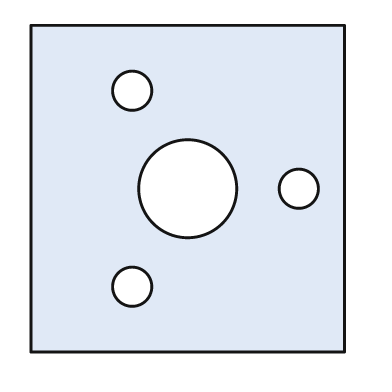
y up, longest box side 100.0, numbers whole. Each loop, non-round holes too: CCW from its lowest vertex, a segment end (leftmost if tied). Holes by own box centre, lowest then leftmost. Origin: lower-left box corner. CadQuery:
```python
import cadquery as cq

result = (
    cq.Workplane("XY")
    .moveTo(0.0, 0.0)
    .lineTo(96.0, 0.0)
    .lineTo(96.0, 100.0)
    .lineTo(0.0, 100.0)
    .close()
    .moveTo(31.0, 20.0)
    .circle(6.0)
    .moveTo(48.0, 50.0)
    .circle(15.0)
    .moveTo(82.0, 50.0)
    .circle(6.0)
    .moveTo(31.0, 80.0)
    .circle(6.0)
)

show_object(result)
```